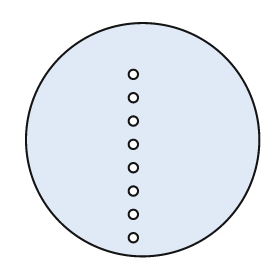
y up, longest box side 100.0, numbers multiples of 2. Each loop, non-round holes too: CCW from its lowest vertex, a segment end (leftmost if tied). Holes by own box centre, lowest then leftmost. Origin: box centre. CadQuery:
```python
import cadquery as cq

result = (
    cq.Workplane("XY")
    .moveTo(0.0, 0.0)
    .circle(50.0)
    .moveTo(-4.0, -42.0)
    .circle(2.0)
    .moveTo(-4.0, -32.0)
    .circle(2.0)
    .moveTo(-4.0, -22.0)
    .circle(2.0)
    .moveTo(-4.0, -12.0)
    .circle(2.0)
    .moveTo(-4.0, -2.0)
    .circle(2.0)
    .moveTo(-4.0, 8.0)
    .circle(2.0)
    .moveTo(-4.0, 18.0)
    .circle(2.0)
    .moveTo(-4.0, 28.0)
    .circle(2.0)
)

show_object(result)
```